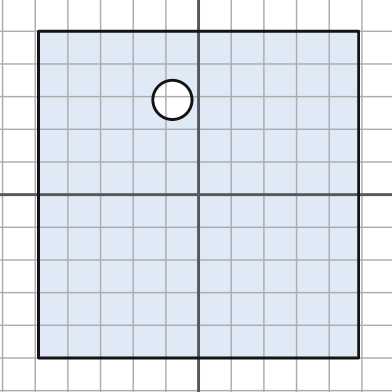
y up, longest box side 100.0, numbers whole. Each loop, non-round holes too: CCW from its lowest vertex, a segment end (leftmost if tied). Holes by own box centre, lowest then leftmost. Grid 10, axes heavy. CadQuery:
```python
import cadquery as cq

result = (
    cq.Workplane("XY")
    .moveTo(-49.0, -50.0)
    .lineTo(49.0, -50.0)
    .lineTo(49.0, 50.0)
    .lineTo(-49.0, 50.0)
    .close()
    .moveTo(-8.0, 29.0)
    .circle(6.0)
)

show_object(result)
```